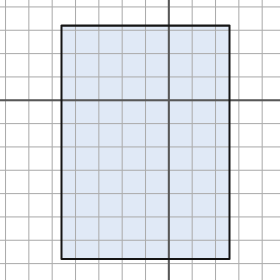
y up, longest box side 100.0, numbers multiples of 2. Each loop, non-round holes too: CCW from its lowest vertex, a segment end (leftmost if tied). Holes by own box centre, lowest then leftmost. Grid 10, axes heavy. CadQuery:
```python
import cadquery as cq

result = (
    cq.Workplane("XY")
    .moveTo(-46.0, -68.0)
    .lineTo(26.0, -68.0)
    .lineTo(26.0, 32.0)
    .lineTo(-46.0, 32.0)
    .close()
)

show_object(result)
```